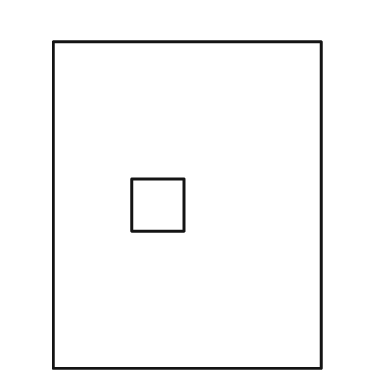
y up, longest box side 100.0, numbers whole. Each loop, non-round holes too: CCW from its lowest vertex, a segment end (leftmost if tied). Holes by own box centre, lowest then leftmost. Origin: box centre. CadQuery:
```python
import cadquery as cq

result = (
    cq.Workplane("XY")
    .moveTo(-41.0, -50.0)
    .lineTo(41.0, -50.0)
    .lineTo(41.0, 50.0)
    .lineTo(-41.0, 50.0)
    .close()
    .moveTo(-17.0, -8.0)
    .lineTo(-1.0, -8.0)
    .lineTo(-1.0, 8.0)
    .lineTo(-17.0, 8.0)
    .close()
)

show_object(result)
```